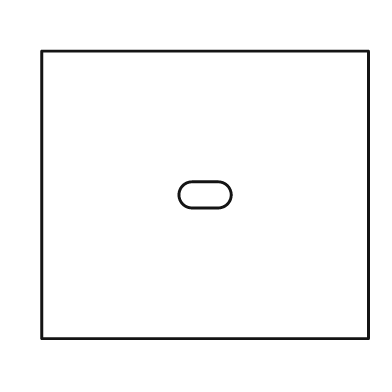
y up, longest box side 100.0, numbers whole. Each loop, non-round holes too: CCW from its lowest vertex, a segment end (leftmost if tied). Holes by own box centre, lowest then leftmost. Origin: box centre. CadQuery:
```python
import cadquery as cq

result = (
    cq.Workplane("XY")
    .moveTo(-50.0, -44.0)
    .lineTo(50.0, -44.0)
    .lineTo(50.0, 44.0)
    .lineTo(-50.0, 44.0)
    .close()
    .moveTo(-4.0, -4.0)
    .lineTo(4.0, -4.0)
    .threePointArc((8.0, 0.0), (4.0, 4.0))
    .lineTo(-4.0, 4.0)
    .threePointArc((-8.0, 0.0), (-4.0, -4.0))
    .close()
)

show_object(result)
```